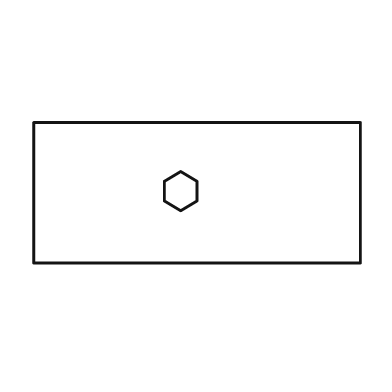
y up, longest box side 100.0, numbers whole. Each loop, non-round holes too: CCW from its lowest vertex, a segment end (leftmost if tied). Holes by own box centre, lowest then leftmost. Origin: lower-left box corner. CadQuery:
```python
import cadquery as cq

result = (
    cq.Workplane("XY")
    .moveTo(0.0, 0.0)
    .lineTo(100.0, 0.0)
    .lineTo(100.0, 43.0)
    .lineTo(0.0, 43.0)
    .close()
    .moveTo(45.0, 16.0)
    .lineTo(50.0, 19.0)
    .lineTo(50.0, 25.0)
    .lineTo(45.0, 28.0)
    .lineTo(40.0, 25.0)
    .lineTo(40.0, 19.0)
    .close()
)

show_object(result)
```